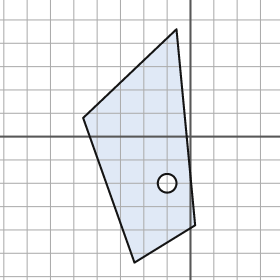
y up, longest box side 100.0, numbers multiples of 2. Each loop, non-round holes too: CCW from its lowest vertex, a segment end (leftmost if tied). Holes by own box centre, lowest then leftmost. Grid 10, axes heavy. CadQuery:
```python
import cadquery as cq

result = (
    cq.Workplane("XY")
    .moveTo(-24.0, -54.0)
    .lineTo(2.0, -38.0)
    .lineTo(-6.0, 46.0)
    .lineTo(-46.0, 8.0)
    .close()
    .moveTo(-10.0, -20.0)
    .circle(4.0)
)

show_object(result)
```